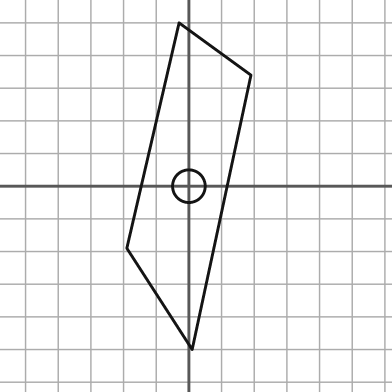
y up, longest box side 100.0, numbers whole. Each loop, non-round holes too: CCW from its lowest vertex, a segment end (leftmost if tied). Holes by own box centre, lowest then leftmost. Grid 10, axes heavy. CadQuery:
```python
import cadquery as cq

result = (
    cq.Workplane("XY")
    .moveTo(1.0, -50.0)
    .lineTo(19.0, 34.0)
    .lineTo(-3.0, 50.0)
    .lineTo(-19.0, -19.0)
    .close()
    .moveTo(0.0, 0.0)
    .circle(5.0)
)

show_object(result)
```